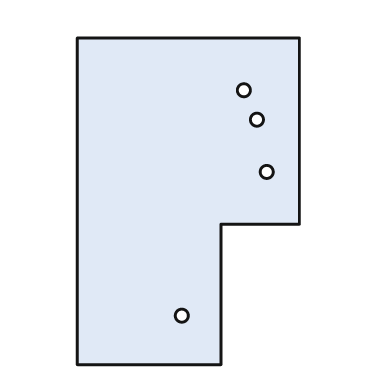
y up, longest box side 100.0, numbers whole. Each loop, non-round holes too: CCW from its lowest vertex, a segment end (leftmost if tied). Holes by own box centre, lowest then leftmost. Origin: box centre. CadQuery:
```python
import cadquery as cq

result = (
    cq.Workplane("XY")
    .moveTo(-34.0, -50.0)
    .lineTo(10.0, -50.0)
    .lineTo(10.0, -7.0)
    .lineTo(34.0, -7.0)
    .lineTo(34.0, 50.0)
    .lineTo(-34.0, 50.0)
    .close()
    .moveTo(-2.0, -35.0)
    .circle(2.0)
    .moveTo(24.0, 9.0)
    .circle(2.0)
    .moveTo(21.0, 25.0)
    .circle(2.0)
    .moveTo(17.0, 34.0)
    .circle(2.0)
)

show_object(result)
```